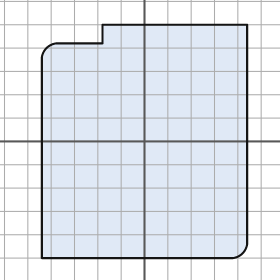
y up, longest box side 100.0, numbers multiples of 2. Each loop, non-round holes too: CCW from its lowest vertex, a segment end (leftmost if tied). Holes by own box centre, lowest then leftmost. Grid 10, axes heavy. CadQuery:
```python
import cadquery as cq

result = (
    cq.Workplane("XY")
    .moveTo(-44.0, -50.0)
    .lineTo(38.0, -50.0)
    .threePointArc((42.0, -48.0), (44.0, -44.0))
    .lineTo(44.0, 50.0)
    .lineTo(-18.0, 50.0)
    .lineTo(-18.0, 42.0)
    .lineTo(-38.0, 42.0)
    .threePointArc((-42.0, 40.0), (-44.0, 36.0))
    .close()
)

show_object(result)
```